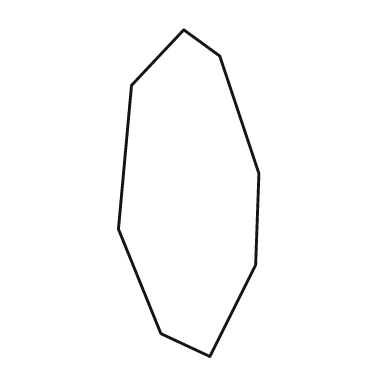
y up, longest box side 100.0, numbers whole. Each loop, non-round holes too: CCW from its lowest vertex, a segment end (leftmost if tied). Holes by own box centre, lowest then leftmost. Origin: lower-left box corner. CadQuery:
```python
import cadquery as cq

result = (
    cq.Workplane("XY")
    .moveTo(28.0, 0.0)
    .lineTo(42.0, 28.0)
    .lineTo(43.0, 56.0)
    .lineTo(31.0, 92.0)
    .lineTo(20.0, 100.0)
    .lineTo(4.0, 83.0)
    .lineTo(0.0, 39.0)
    .lineTo(13.0, 7.0)
    .close()
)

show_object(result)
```